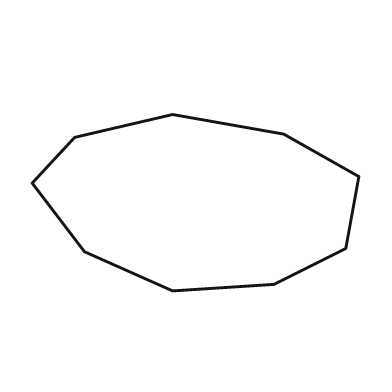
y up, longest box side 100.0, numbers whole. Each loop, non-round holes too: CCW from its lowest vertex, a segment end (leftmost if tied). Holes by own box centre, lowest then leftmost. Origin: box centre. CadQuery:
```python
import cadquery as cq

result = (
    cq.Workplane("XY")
    .moveTo(-7.0, -27.0)
    .lineTo(24.0, -25.0)
    .lineTo(46.0, -14.0)
    .lineTo(50.0, 8.0)
    .lineTo(27.0, 21.0)
    .lineTo(-7.0, 27.0)
    .lineTo(-37.0, 20.0)
    .lineTo(-50.0, 6.0)
    .lineTo(-34.0, -15.0)
    .close()
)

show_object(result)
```